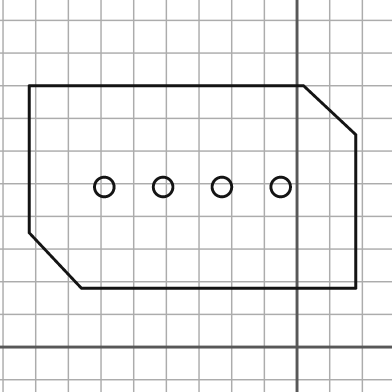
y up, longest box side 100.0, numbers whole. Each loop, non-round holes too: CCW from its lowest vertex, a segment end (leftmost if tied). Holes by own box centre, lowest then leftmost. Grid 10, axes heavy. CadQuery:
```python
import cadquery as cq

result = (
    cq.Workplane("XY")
    .moveTo(-66.0, 18.0)
    .lineTo(18.0, 18.0)
    .lineTo(18.0, 65.0)
    .lineTo(2.0, 80.0)
    .lineTo(-82.0, 80.0)
    .lineTo(-82.0, 35.0)
    .close()
    .moveTo(-59.0, 49.0)
    .circle(3.0)
    .moveTo(-41.0, 49.0)
    .circle(3.0)
    .moveTo(-23.0, 49.0)
    .circle(3.0)
    .moveTo(-5.0, 49.0)
    .circle(3.0)
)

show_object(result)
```